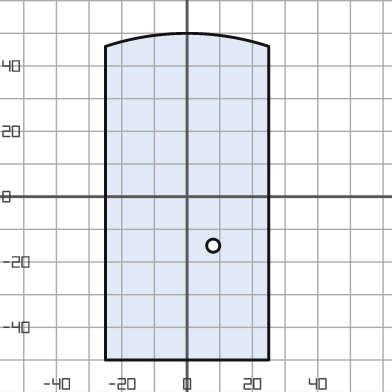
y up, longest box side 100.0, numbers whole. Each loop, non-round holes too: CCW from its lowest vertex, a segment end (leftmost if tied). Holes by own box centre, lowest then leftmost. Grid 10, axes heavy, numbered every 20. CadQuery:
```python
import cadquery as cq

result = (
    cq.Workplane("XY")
    .moveTo(-25.0, -50.0)
    .lineTo(25.0, -50.0)
    .lineTo(25.0, 46.0)
    .threePointArc((0.0, 50.0), (-25.0, 46.0))
    .close()
    .moveTo(8.0, -15.0)
    .circle(2.0)
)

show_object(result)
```